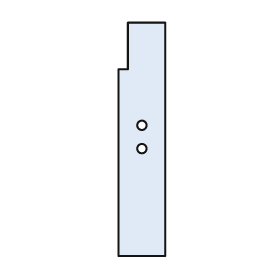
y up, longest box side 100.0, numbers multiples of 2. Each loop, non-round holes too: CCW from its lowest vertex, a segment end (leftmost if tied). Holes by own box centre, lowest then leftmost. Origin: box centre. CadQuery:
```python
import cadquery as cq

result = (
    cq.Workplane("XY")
    .moveTo(-10.0, -50.0)
    .lineTo(10.0, -50.0)
    .lineTo(10.0, 50.0)
    .lineTo(-6.0, 50.0)
    .lineTo(-6.0, 30.0)
    .lineTo(-10.0, 30.0)
    .close()
    .moveTo(0.0, -4.0)
    .circle(2.0)
    .moveTo(0.0, 6.0)
    .circle(2.0)
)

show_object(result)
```